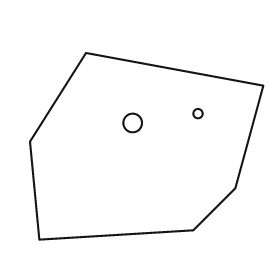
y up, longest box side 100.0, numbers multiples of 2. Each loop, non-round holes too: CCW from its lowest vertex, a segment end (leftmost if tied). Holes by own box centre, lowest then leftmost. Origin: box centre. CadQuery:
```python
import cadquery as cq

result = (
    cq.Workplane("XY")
    .moveTo(-46.0, -40.0)
    .lineTo(20.0, -36.0)
    .lineTo(38.0, -18.0)
    .lineTo(50.0, 26.0)
    .lineTo(-26.0, 40.0)
    .lineTo(-50.0, 2.0)
    .close()
    .moveTo(-6.0, 10.0)
    .circle(4.0)
    .moveTo(22.0, 14.0)
    .circle(2.0)
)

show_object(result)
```